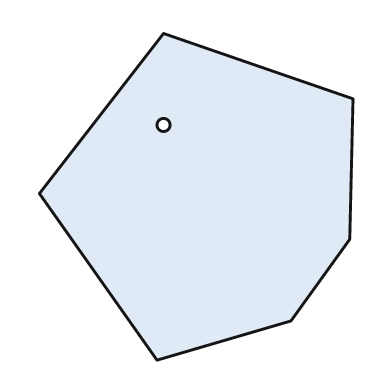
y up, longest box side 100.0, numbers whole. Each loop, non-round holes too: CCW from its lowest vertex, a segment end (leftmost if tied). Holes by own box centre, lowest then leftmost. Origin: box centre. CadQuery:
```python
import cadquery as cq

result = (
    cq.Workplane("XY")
    .moveTo(-12.0, -50.0)
    .lineTo(29.0, -38.0)
    .lineTo(47.0, -13.0)
    .lineTo(48.0, 30.0)
    .lineTo(-10.0, 50.0)
    .lineTo(-48.0, 1.0)
    .close()
    .moveTo(-10.0, 22.0)
    .circle(2.0)
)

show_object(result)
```